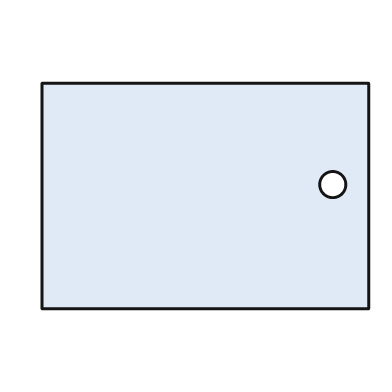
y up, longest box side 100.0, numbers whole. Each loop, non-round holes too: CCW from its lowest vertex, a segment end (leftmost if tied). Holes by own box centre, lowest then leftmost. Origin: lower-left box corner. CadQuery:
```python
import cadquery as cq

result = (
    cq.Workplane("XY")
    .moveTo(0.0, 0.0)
    .lineTo(100.0, 0.0)
    .lineTo(100.0, 69.0)
    .lineTo(0.0, 69.0)
    .close()
    .moveTo(89.0, 38.0)
    .circle(4.0)
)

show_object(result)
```